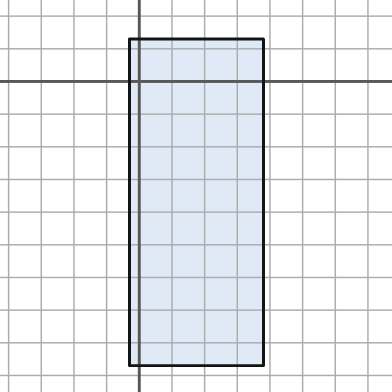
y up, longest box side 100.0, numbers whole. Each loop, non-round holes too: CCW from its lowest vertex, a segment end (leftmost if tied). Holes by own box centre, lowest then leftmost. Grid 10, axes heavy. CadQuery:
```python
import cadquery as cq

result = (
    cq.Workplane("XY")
    .moveTo(-3.0, -87.0)
    .lineTo(38.0, -87.0)
    .lineTo(38.0, 13.0)
    .lineTo(-3.0, 13.0)
    .close()
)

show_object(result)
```